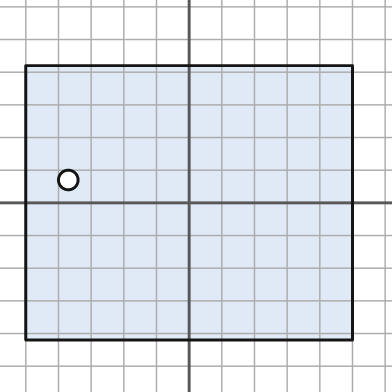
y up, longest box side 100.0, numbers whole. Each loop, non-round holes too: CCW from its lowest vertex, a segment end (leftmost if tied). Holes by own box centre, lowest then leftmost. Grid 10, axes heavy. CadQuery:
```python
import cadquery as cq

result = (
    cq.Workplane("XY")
    .moveTo(-50.0, -42.0)
    .lineTo(50.0, -42.0)
    .lineTo(50.0, 42.0)
    .lineTo(-50.0, 42.0)
    .close()
    .moveTo(-37.0, 7.0)
    .circle(3.0)
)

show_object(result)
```